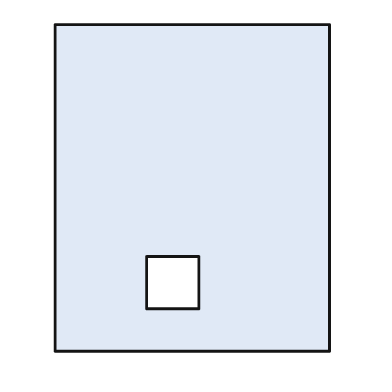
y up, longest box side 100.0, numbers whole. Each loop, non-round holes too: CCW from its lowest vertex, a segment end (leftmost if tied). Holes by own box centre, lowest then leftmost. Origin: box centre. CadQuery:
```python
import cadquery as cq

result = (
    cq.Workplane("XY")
    .moveTo(-42.0, -50.0)
    .lineTo(42.0, -50.0)
    .lineTo(42.0, 50.0)
    .lineTo(-42.0, 50.0)
    .close()
    .moveTo(-14.0, -37.0)
    .lineTo(2.0, -37.0)
    .lineTo(2.0, -21.0)
    .lineTo(-14.0, -21.0)
    .close()
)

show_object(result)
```